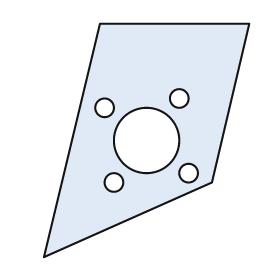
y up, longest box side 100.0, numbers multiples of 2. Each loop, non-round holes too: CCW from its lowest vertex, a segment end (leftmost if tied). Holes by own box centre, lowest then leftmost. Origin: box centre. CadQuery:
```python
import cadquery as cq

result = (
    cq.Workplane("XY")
    .moveTo(-44.0, -50.0)
    .lineTo(28.0, -18.0)
    .lineTo(44.0, 50.0)
    .lineTo(-20.0, 50.0)
    .close()
    .moveTo(-14.0, -18.0)
    .circle(4.0)
    .moveTo(18.0, -14.0)
    .circle(4.0)
    .moveTo(0.0, 0.0)
    .circle(14.0)
    .moveTo(-18.0, 14.0)
    .circle(4.0)
    .moveTo(14.0, 18.0)
    .circle(4.0)
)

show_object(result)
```